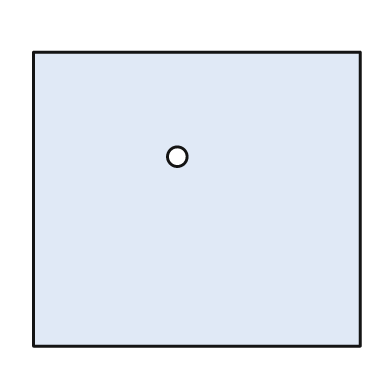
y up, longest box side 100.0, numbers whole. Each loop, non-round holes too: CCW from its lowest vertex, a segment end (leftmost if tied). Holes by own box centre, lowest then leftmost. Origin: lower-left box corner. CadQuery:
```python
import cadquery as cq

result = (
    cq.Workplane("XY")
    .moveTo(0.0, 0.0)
    .lineTo(100.0, 0.0)
    .lineTo(100.0, 90.0)
    .lineTo(0.0, 90.0)
    .close()
    .moveTo(44.0, 58.0)
    .circle(3.0)
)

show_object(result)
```